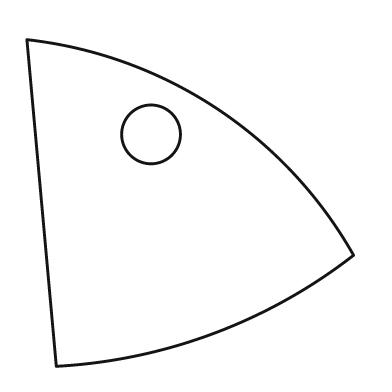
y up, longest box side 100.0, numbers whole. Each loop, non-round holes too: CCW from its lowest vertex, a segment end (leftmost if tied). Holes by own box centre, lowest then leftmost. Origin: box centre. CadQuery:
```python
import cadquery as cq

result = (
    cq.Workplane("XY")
    .moveTo(-41.0, -50.0)
    .threePointArc((7.0, -40.0), (50.0, -16.0))
    .threePointArc((8.0, 29.0), (-50.0, 50.0))
    .close()
    .moveTo(-12.0, 21.0)
    .circle(9.0)
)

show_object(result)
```